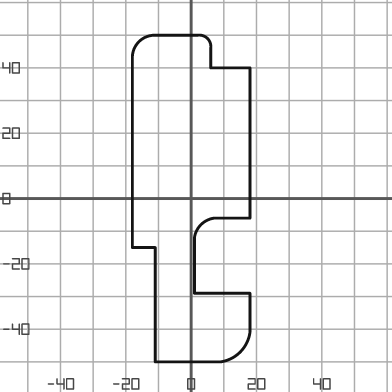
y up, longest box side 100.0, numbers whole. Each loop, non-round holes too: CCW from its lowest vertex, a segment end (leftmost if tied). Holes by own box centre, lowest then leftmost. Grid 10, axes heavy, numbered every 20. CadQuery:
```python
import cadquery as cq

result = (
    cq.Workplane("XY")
    .moveTo(-11.0, -50.0)
    .lineTo(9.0, -50.0)
    .threePointArc((15.0, -47.0), (18.0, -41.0))
    .lineTo(18.0, -29.0)
    .lineTo(1.0, -29.0)
    .lineTo(1.0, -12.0)
    .threePointArc((3.0, -8.0), (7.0, -6.0))
    .lineTo(18.0, -6.0)
    .lineTo(18.0, 40.0)
    .lineTo(6.0, 40.0)
    .lineTo(6.0, 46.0)
    .threePointArc((5.0, 49.0), (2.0, 50.0))
    .lineTo(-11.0, 50.0)
    .threePointArc((-16.0, 48.0), (-18.0, 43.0))
    .lineTo(-18.0, -15.0)
    .lineTo(-11.0, -15.0)
    .close()
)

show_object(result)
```